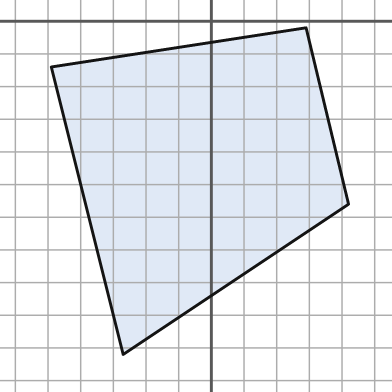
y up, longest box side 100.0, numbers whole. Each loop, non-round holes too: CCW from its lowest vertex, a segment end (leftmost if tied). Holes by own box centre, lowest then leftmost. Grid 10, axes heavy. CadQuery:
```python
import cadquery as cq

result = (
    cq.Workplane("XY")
    .moveTo(-27.0, -102.0)
    .lineTo(42.0, -56.0)
    .lineTo(29.0, -2.0)
    .lineTo(-49.0, -14.0)
    .close()
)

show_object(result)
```